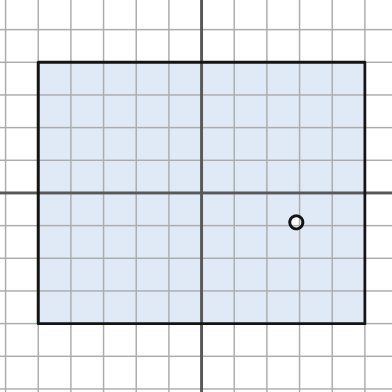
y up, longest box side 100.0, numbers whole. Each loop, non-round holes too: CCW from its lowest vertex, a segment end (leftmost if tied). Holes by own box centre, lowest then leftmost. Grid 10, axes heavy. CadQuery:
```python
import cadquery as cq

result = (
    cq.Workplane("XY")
    .moveTo(-50.0, -40.0)
    .lineTo(50.0, -40.0)
    .lineTo(50.0, 40.0)
    .lineTo(-50.0, 40.0)
    .close()
    .moveTo(29.0, -9.0)
    .circle(2.0)
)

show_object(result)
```